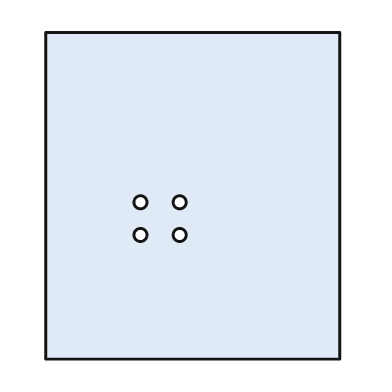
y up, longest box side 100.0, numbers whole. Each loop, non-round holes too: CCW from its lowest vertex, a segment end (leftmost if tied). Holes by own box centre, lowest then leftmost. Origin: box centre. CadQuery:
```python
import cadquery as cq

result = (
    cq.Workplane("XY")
    .moveTo(-45.0, -50.0)
    .lineTo(45.0, -50.0)
    .lineTo(45.0, 50.0)
    .lineTo(-45.0, 50.0)
    .close()
    .moveTo(-16.0, -12.0)
    .circle(2.0)
    .moveTo(-4.0, -12.0)
    .circle(2.0)
    .moveTo(-16.0, -2.0)
    .circle(2.0)
    .moveTo(-4.0, -2.0)
    .circle(2.0)
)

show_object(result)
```